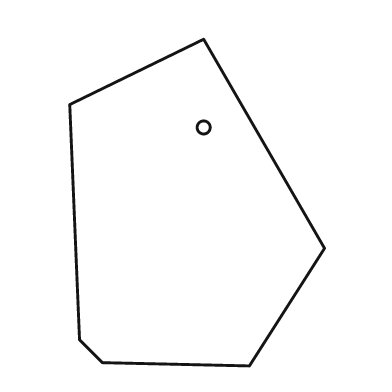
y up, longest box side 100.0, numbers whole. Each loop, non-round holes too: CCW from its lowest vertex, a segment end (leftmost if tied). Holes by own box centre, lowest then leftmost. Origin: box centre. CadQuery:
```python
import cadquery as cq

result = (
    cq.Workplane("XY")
    .moveTo(16.0, -50.0)
    .lineTo(39.0, -14.0)
    .lineTo(2.0, 50.0)
    .lineTo(-39.0, 30.0)
    .lineTo(-36.0, -42.0)
    .lineTo(-29.0, -49.0)
    .close()
    .moveTo(2.0, 23.0)
    .circle(2.0)
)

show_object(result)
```